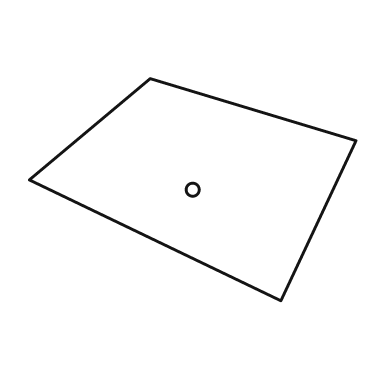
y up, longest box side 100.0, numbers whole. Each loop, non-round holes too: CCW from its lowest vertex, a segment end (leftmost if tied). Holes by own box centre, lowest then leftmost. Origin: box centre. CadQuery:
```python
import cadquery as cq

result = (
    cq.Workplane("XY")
    .moveTo(27.0, -34.0)
    .lineTo(50.0, 15.0)
    .lineTo(-13.0, 34.0)
    .lineTo(-50.0, 3.0)
    .close()
    .moveTo(0.0, 0.0)
    .circle(2.0)
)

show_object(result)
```